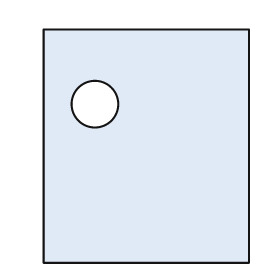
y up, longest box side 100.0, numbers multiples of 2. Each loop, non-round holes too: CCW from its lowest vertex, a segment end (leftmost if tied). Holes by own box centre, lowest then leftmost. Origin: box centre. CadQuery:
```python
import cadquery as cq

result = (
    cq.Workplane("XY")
    .moveTo(-44.0, -50.0)
    .lineTo(44.0, -50.0)
    .lineTo(44.0, 50.0)
    .lineTo(-44.0, 50.0)
    .close()
    .moveTo(-22.0, 18.0)
    .circle(10.0)
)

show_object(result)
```